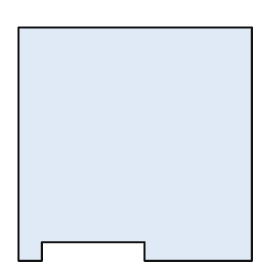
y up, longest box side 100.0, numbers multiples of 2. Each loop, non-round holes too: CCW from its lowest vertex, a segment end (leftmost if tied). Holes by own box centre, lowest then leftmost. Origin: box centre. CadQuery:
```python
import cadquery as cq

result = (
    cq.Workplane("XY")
    .moveTo(-50.0, -50.0)
    .lineTo(-40.0, -50.0)
    .lineTo(-40.0, -42.0)
    .lineTo(4.0, -42.0)
    .lineTo(4.0, -50.0)
    .lineTo(50.0, -50.0)
    .lineTo(50.0, 50.0)
    .lineTo(-50.0, 50.0)
    .close()
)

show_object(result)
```